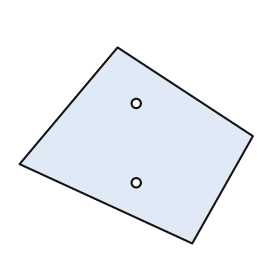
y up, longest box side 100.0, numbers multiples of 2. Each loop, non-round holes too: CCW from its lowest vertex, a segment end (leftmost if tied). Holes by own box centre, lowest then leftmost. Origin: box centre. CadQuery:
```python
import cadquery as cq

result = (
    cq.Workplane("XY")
    .moveTo(24.0, -42.0)
    .lineTo(50.0, 4.0)
    .lineTo(-8.0, 42.0)
    .lineTo(-50.0, -8.0)
    .close()
    .moveTo(0.0, -16.0)
    .circle(2.0)
    .moveTo(0.0, 18.0)
    .circle(2.0)
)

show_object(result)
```